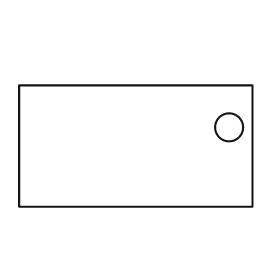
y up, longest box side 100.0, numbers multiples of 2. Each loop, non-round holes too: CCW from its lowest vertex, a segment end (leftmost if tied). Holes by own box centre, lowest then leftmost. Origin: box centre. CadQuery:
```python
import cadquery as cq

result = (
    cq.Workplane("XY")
    .moveTo(-50.0, -26.0)
    .lineTo(50.0, -26.0)
    .lineTo(50.0, 26.0)
    .lineTo(-50.0, 26.0)
    .close()
    .moveTo(40.0, 8.0)
    .circle(6.0)
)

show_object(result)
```